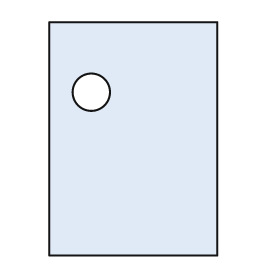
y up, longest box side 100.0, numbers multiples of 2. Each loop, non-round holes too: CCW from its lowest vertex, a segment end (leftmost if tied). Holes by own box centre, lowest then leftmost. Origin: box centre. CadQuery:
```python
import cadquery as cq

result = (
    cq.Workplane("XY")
    .moveTo(-36.0, -50.0)
    .lineTo(36.0, -50.0)
    .lineTo(36.0, 50.0)
    .lineTo(-36.0, 50.0)
    .close()
    .moveTo(-18.0, 20.0)
    .circle(8.0)
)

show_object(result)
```